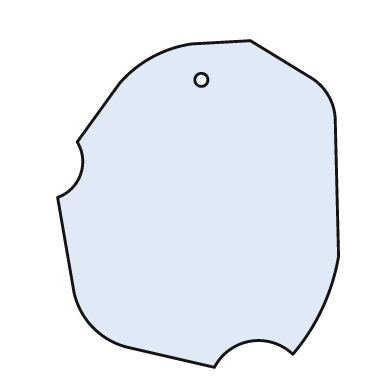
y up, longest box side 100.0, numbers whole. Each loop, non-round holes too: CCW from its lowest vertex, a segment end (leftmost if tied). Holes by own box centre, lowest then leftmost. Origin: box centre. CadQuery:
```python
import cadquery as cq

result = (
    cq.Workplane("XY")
    .moveTo(5.0, -50.0)
    .threePointArc((16.0, -42.0), (29.0, -46.0))
    .threePointArc((38.0, -32.0), (43.0, -16.0))
    .lineTo(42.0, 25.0)
    .threePointArc((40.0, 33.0), (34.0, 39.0))
    .lineTo(16.0, 50.0)
    .lineTo(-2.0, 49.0)
    .threePointArc((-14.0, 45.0), (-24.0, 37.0))
    .lineTo(-37.0, 19.0)
    .threePointArc((-36.0, 9.0), (-43.0, 2.0))
    .lineTo(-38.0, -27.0)
    .threePointArc((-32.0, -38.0), (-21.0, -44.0))
    .close()
    .moveTo(1.0, 38.0)
    .circle(2.0)
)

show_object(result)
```